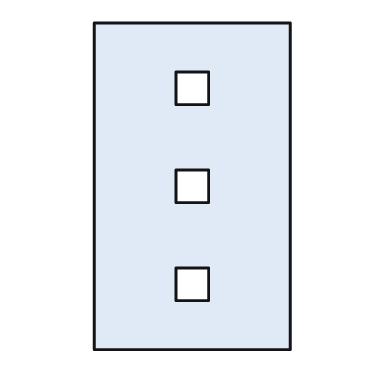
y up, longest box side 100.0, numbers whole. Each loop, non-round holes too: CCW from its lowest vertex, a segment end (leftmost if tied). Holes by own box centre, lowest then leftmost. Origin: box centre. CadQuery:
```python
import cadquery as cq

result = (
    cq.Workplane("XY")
    .moveTo(-30.0, -50.0)
    .lineTo(30.0, -50.0)
    .lineTo(30.0, 50.0)
    .lineTo(-30.0, 50.0)
    .close()
    .moveTo(-5.0, -35.0)
    .lineTo(5.0, -35.0)
    .lineTo(5.0, -25.0)
    .lineTo(-5.0, -25.0)
    .close()
    .moveTo(-5.0, -5.0)
    .lineTo(5.0, -5.0)
    .lineTo(5.0, 5.0)
    .lineTo(-5.0, 5.0)
    .close()
    .moveTo(-5.0, 25.0)
    .lineTo(5.0, 25.0)
    .lineTo(5.0, 35.0)
    .lineTo(-5.0, 35.0)
    .close()
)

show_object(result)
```